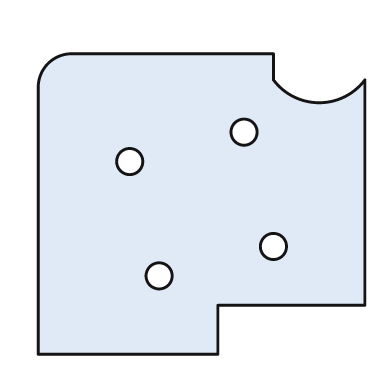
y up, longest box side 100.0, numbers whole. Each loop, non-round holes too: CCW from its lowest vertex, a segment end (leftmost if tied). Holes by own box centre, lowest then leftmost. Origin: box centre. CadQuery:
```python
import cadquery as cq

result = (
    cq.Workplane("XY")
    .moveTo(-50.0, -46.0)
    .lineTo(5.0, -46.0)
    .lineTo(5.0, -31.0)
    .lineTo(50.0, -31.0)
    .lineTo(50.0, 38.0)
    .threePointArc((36.0, 31.0), (22.0, 38.0))
    .lineTo(22.0, 46.0)
    .lineTo(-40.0, 46.0)
    .threePointArc((-47.0, 43.0), (-50.0, 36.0))
    .close()
    .moveTo(-13.0, -22.0)
    .circle(4.0)
    .moveTo(22.0, -13.0)
    .circle(4.0)
    .moveTo(-22.0, 13.0)
    .circle(4.0)
    .moveTo(13.0, 22.0)
    .circle(4.0)
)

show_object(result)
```